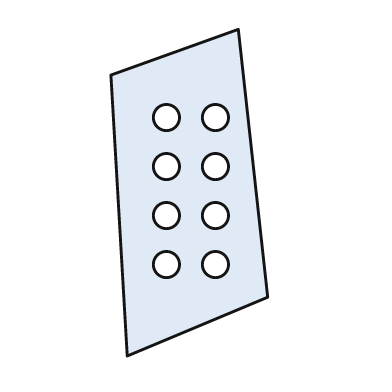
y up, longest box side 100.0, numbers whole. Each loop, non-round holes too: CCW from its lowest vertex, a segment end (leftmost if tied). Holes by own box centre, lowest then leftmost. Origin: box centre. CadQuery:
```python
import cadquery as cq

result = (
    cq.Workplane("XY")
    .moveTo(-19.0, -50.0)
    .lineTo(24.0, -32.0)
    .lineTo(15.0, 50.0)
    .lineTo(-24.0, 36.0)
    .close()
    .moveTo(-7.0, -22.0)
    .circle(4.0)
    .moveTo(8.0, -22.0)
    .circle(4.0)
    .moveTo(-7.0, -7.0)
    .circle(4.0)
    .moveTo(8.0, -7.0)
    .circle(4.0)
    .moveTo(-7.0, 8.0)
    .circle(4.0)
    .moveTo(8.0, 8.0)
    .circle(4.0)
    .moveTo(-7.0, 23.0)
    .circle(4.0)
    .moveTo(8.0, 23.0)
    .circle(4.0)
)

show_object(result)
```